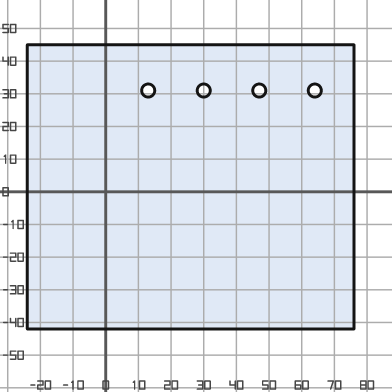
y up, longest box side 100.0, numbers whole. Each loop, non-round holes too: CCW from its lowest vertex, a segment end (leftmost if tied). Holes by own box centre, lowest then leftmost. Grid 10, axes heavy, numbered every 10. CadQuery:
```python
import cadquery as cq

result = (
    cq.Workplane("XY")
    .moveTo(-24.0, -42.0)
    .lineTo(76.0, -42.0)
    .lineTo(76.0, 45.0)
    .lineTo(-24.0, 45.0)
    .close()
    .moveTo(13.0, 31.0)
    .circle(2.0)
    .moveTo(30.0, 31.0)
    .circle(2.0)
    .moveTo(47.0, 31.0)
    .circle(2.0)
    .moveTo(64.0, 31.0)
    .circle(2.0)
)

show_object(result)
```